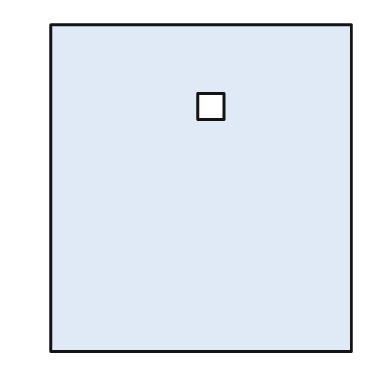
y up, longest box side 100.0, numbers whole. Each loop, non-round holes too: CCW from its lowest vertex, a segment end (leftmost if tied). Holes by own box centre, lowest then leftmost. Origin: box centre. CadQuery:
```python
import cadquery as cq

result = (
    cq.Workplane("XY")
    .moveTo(-46.0, -50.0)
    .lineTo(46.0, -50.0)
    .lineTo(46.0, 50.0)
    .lineTo(-46.0, 50.0)
    .close()
    .moveTo(-1.0, 21.0)
    .lineTo(7.0, 21.0)
    .lineTo(7.0, 29.0)
    .lineTo(-1.0, 29.0)
    .close()
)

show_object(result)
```